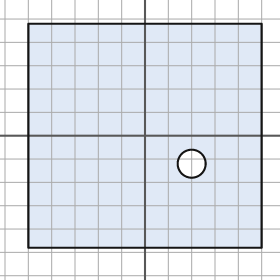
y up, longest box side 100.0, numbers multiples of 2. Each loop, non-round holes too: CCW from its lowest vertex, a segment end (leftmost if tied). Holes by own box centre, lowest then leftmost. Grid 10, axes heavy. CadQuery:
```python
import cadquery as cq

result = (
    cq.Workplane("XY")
    .moveTo(-50.0, -48.0)
    .lineTo(50.0, -48.0)
    .lineTo(50.0, 48.0)
    .lineTo(-50.0, 48.0)
    .close()
    .moveTo(20.0, -12.0)
    .circle(6.0)
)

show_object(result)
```